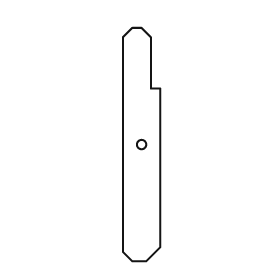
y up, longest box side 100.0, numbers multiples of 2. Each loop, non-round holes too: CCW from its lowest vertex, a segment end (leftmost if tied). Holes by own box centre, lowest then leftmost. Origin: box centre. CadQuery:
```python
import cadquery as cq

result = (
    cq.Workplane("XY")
    .moveTo(-4.0, -50.0)
    .lineTo(2.0, -50.0)
    .lineTo(8.0, -44.0)
    .lineTo(8.0, 24.0)
    .lineTo(4.0, 24.0)
    .lineTo(4.0, 46.0)
    .lineTo(0.0, 50.0)
    .lineTo(-4.0, 50.0)
    .lineTo(-8.0, 46.0)
    .lineTo(-8.0, -46.0)
    .close()
    .moveTo(0.0, 0.0)
    .circle(2.0)
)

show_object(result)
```